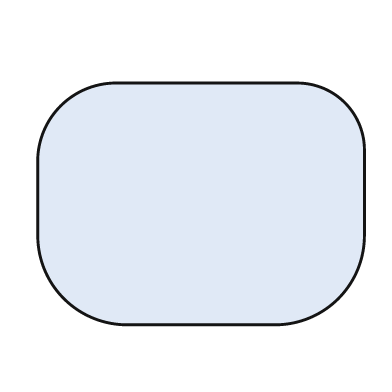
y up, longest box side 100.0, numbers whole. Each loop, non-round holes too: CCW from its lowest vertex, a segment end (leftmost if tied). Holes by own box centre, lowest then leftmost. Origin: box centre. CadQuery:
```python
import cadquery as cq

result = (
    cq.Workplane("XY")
    .moveTo(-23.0, -37.0)
    .lineTo(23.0, -37.0)
    .threePointArc((42.0, -29.0), (50.0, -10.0))
    .lineTo(50.0, 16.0)
    .threePointArc((44.0, 31.0), (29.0, 37.0))
    .lineTo(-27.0, 37.0)
    .threePointArc((-43.0, 30.0), (-50.0, 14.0))
    .lineTo(-50.0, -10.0)
    .threePointArc((-42.0, -29.0), (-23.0, -37.0))
    .close()
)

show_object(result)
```